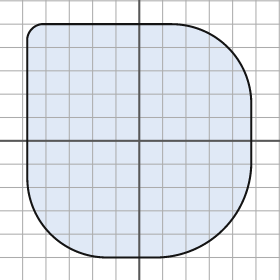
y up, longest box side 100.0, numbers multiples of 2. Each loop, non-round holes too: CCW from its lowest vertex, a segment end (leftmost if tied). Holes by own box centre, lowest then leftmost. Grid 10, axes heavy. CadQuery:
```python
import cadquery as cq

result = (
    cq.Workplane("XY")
    .moveTo(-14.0, -50.0)
    .lineTo(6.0, -50.0)
    .threePointArc((36.0, -38.0), (48.0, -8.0))
    .lineTo(48.0, 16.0)
    .threePointArc((38.0, 40.0), (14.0, 50.0))
    .lineTo(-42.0, 50.0)
    .threePointArc((-46.0, 48.0), (-48.0, 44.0))
    .lineTo(-48.0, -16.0)
    .threePointArc((-38.0, -40.0), (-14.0, -50.0))
    .close()
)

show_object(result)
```